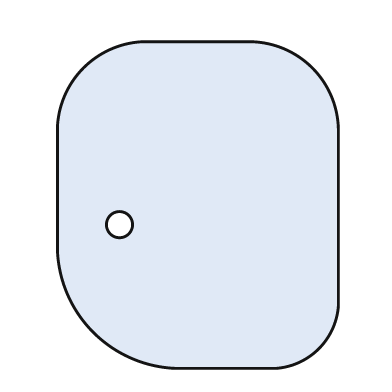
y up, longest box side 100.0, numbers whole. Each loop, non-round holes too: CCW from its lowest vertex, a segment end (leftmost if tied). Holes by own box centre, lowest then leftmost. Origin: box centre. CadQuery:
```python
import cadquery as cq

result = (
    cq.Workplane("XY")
    .moveTo(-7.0, -50.0)
    .lineTo(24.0, -50.0)
    .threePointArc((37.0, -44.0), (43.0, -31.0))
    .lineTo(43.0, 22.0)
    .threePointArc((35.0, 42.0), (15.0, 50.0))
    .lineTo(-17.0, 50.0)
    .threePointArc((-35.0, 42.0), (-43.0, 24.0))
    .lineTo(-43.0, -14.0)
    .threePointArc((-32.0, -39.0), (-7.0, -50.0))
    .close()
    .moveTo(-24.0, -6.0)
    .circle(4.0)
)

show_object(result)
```